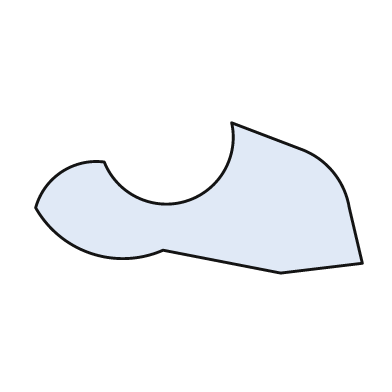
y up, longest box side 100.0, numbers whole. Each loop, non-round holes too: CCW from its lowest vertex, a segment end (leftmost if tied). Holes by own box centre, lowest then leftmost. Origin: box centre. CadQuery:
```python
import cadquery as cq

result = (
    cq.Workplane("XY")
    .moveTo(25.0, -23.0)
    .lineTo(50.0, -20.0)
    .lineTo(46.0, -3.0)
    .threePointArc((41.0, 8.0), (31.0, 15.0))
    .lineTo(10.0, 23.0)
    .threePointArc((-4.0, -1.0), (-29.0, 11.0))
    .threePointArc((-42.0, 8.0), (-50.0, -3.0))
    .threePointArc((-33.0, -17.0), (-11.0, -16.0))
    .close()
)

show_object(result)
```